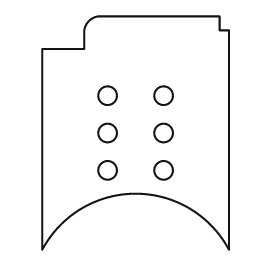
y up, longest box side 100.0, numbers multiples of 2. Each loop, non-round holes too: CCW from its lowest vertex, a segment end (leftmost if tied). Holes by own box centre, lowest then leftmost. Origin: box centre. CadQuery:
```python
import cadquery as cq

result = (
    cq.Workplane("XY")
    .moveTo(-40.0, -50.0)
    .threePointArc((0.0, -26.0), (40.0, -50.0))
    .lineTo(40.0, 44.0)
    .lineTo(36.0, 44.0)
    .lineTo(36.0, 50.0)
    .lineTo(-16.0, 50.0)
    .threePointArc((-20.0, 48.0), (-22.0, 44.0))
    .lineTo(-22.0, 36.0)
    .lineTo(-40.0, 36.0)
    .close()
    .moveTo(-12.0, -16.0)
    .circle(4.0)
    .moveTo(12.0, -16.0)
    .circle(4.0)
    .moveTo(-12.0, 0.0)
    .circle(4.0)
    .moveTo(12.0, 0.0)
    .circle(4.0)
    .moveTo(-12.0, 16.0)
    .circle(4.0)
    .moveTo(12.0, 16.0)
    .circle(4.0)
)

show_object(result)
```